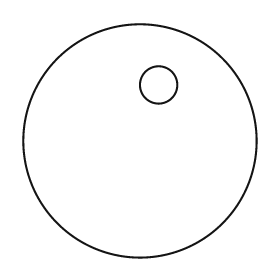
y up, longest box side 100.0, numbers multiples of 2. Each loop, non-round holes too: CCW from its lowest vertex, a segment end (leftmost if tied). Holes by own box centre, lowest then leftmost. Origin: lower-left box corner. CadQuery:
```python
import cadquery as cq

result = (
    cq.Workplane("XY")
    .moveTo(50.0, 50.0)
    .circle(50.0)
    .moveTo(58.0, 74.0)
    .circle(8.0)
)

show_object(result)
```